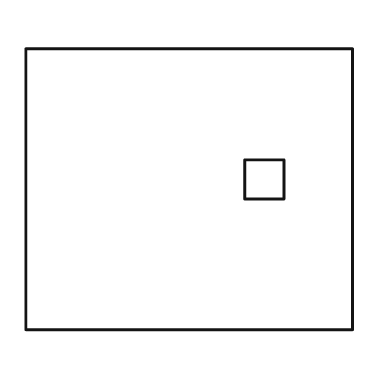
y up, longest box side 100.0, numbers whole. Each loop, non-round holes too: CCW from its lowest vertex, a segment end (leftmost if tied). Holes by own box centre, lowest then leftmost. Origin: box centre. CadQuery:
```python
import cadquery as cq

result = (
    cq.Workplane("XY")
    .moveTo(-50.0, -43.0)
    .lineTo(50.0, -43.0)
    .lineTo(50.0, 43.0)
    .lineTo(-50.0, 43.0)
    .close()
    .moveTo(17.0, -3.0)
    .lineTo(29.0, -3.0)
    .lineTo(29.0, 9.0)
    .lineTo(17.0, 9.0)
    .close()
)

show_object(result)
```